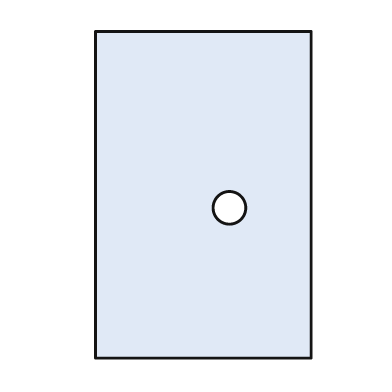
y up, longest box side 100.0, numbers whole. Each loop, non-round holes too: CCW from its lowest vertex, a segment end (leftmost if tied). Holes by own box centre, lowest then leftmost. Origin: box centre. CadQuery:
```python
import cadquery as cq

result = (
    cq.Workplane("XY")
    .moveTo(-33.0, -50.0)
    .lineTo(33.0, -50.0)
    .lineTo(33.0, 50.0)
    .lineTo(-33.0, 50.0)
    .close()
    .moveTo(8.0, -4.0)
    .circle(5.0)
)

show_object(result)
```